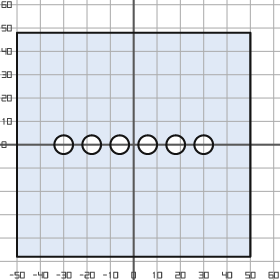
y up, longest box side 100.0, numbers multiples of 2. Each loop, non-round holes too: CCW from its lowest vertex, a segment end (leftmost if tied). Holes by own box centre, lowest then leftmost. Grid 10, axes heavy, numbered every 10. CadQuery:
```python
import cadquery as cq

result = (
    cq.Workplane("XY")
    .moveTo(-50.0, -48.0)
    .lineTo(50.0, -48.0)
    .lineTo(50.0, 48.0)
    .lineTo(-50.0, 48.0)
    .close()
    .moveTo(-30.0, 0.0)
    .circle(4.0)
    .moveTo(-18.0, 0.0)
    .circle(4.0)
    .moveTo(-6.0, 0.0)
    .circle(4.0)
    .moveTo(6.0, 0.0)
    .circle(4.0)
    .moveTo(18.0, 0.0)
    .circle(4.0)
    .moveTo(30.0, 0.0)
    .circle(4.0)
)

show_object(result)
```